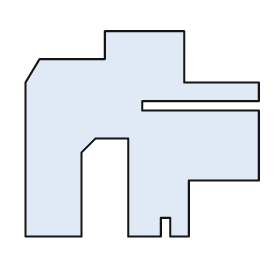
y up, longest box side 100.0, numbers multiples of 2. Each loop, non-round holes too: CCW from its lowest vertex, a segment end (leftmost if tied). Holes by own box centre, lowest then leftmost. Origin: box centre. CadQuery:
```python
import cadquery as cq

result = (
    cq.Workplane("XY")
    .moveTo(-50.0, -44.0)
    .lineTo(-26.0, -44.0)
    .lineTo(-26.0, -8.0)
    .lineTo(-20.0, -2.0)
    .lineTo(-6.0, -2.0)
    .lineTo(-6.0, -44.0)
    .lineTo(8.0, -44.0)
    .lineTo(8.0, -36.0)
    .lineTo(12.0, -36.0)
    .lineTo(12.0, -44.0)
    .lineTo(20.0, -44.0)
    .lineTo(20.0, -20.0)
    .lineTo(50.0, -20.0)
    .lineTo(50.0, 10.0)
    .lineTo(0.0, 10.0)
    .lineTo(0.0, 14.0)
    .lineTo(50.0, 14.0)
    .lineTo(50.0, 22.0)
    .lineTo(18.0, 22.0)
    .lineTo(18.0, 44.0)
    .lineTo(-16.0, 44.0)
    .lineTo(-16.0, 32.0)
    .lineTo(-44.0, 32.0)
    .lineTo(-50.0, 22.0)
    .close()
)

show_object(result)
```